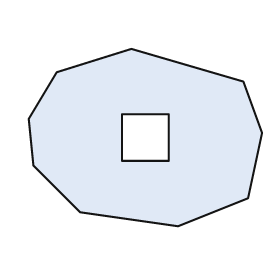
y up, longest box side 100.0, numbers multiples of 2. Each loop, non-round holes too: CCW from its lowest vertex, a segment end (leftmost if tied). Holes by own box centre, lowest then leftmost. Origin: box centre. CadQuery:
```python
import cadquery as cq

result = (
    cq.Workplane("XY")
    .moveTo(14.0, -38.0)
    .lineTo(44.0, -26.0)
    .lineTo(50.0, 2.0)
    .lineTo(42.0, 24.0)
    .lineTo(-6.0, 38.0)
    .lineTo(-38.0, 28.0)
    .lineTo(-50.0, 8.0)
    .lineTo(-48.0, -12.0)
    .lineTo(-28.0, -32.0)
    .close()
    .moveTo(-10.0, -10.0)
    .lineTo(10.0, -10.0)
    .lineTo(10.0, 10.0)
    .lineTo(-10.0, 10.0)
    .close()
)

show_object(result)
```